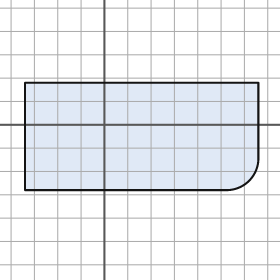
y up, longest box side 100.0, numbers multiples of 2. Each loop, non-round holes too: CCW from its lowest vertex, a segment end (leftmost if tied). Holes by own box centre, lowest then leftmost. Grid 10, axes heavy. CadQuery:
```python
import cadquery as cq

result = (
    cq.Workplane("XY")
    .moveTo(-34.0, -28.0)
    .lineTo(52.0, -28.0)
    .threePointArc((62.0, -24.0), (66.0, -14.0))
    .lineTo(66.0, 18.0)
    .lineTo(-34.0, 18.0)
    .close()
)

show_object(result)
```